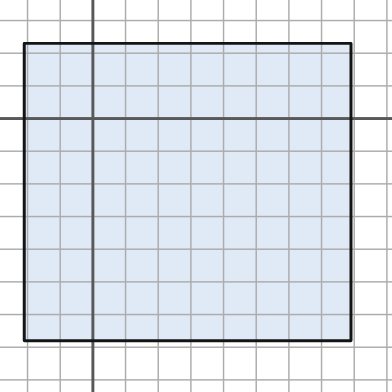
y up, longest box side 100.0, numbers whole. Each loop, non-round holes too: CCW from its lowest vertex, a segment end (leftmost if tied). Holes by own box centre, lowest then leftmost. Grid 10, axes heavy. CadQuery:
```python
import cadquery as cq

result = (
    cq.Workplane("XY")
    .moveTo(-21.0, -68.0)
    .lineTo(79.0, -68.0)
    .lineTo(79.0, 23.0)
    .lineTo(-21.0, 23.0)
    .close()
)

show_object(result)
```